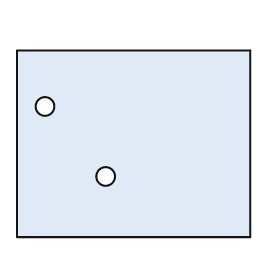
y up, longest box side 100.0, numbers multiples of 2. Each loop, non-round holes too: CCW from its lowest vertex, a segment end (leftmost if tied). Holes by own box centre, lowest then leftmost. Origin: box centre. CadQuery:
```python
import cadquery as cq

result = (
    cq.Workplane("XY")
    .moveTo(-50.0, -40.0)
    .lineTo(50.0, -40.0)
    .lineTo(50.0, 40.0)
    .lineTo(-50.0, 40.0)
    .close()
    .moveTo(-12.0, -14.0)
    .circle(4.0)
    .moveTo(-38.0, 16.0)
    .circle(4.0)
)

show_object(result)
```